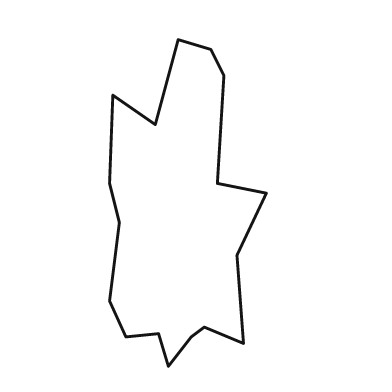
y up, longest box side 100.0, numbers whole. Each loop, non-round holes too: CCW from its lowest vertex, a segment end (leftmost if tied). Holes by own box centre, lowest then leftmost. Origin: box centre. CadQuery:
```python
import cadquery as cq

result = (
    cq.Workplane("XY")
    .moveTo(-6.0, -50.0)
    .lineTo(1.0, -41.0)
    .lineTo(5.0, -38.0)
    .lineTo(17.0, -43.0)
    .lineTo(15.0, -16.0)
    .lineTo(24.0, 3.0)
    .lineTo(9.0, 6.0)
    .lineTo(11.0, 39.0)
    .lineTo(7.0, 47.0)
    .lineTo(-3.0, 50.0)
    .lineTo(-10.0, 24.0)
    .lineTo(-23.0, 33.0)
    .lineTo(-24.0, 6.0)
    .lineTo(-21.0, -6.0)
    .lineTo(-24.0, -30.0)
    .lineTo(-19.0, -41.0)
    .lineTo(-9.0, -40.0)
    .close()
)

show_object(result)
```